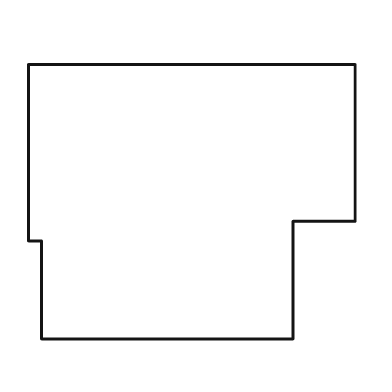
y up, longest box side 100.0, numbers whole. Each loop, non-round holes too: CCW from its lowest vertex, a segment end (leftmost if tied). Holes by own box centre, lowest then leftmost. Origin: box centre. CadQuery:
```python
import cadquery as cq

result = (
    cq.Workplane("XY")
    .moveTo(-46.0, -42.0)
    .lineTo(31.0, -42.0)
    .lineTo(31.0, -6.0)
    .lineTo(50.0, -6.0)
    .lineTo(50.0, 42.0)
    .lineTo(-50.0, 42.0)
    .lineTo(-50.0, -12.0)
    .lineTo(-46.0, -12.0)
    .close()
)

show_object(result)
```